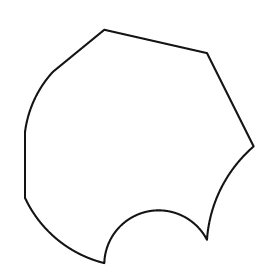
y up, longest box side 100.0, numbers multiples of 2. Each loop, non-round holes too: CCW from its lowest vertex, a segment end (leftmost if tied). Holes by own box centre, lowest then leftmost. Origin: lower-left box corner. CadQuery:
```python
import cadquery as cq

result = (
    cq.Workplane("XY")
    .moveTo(34.0, 0.0)
    .threePointArc((52.0, 22.0), (78.0, 10.0))
    .threePointArc((84.0, 32.0), (98.0, 50.0))
    .lineTo(78.0, 90.0)
    .lineTo(34.0, 100.0)
    .lineTo(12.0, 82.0)
    .threePointArc((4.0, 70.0), (0.0, 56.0))
    .lineTo(0.0, 28.0)
    .threePointArc((14.0, 10.0), (34.0, 0.0))
    .close()
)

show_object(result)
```